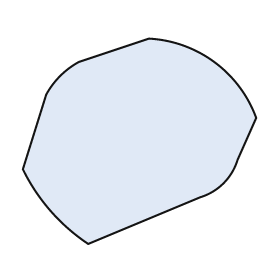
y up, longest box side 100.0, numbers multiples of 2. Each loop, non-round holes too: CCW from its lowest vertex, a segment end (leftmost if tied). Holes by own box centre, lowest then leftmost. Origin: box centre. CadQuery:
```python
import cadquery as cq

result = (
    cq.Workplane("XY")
    .moveTo(-22.0, -44.0)
    .lineTo(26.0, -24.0)
    .threePointArc((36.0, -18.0), (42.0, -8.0))
    .lineTo(50.0, 10.0)
    .threePointArc((32.0, 34.0), (4.0, 44.0))
    .lineTo(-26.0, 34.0)
    .threePointArc((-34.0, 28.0), (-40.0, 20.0))
    .lineTo(-50.0, -12.0)
    .threePointArc((-38.0, -30.0), (-22.0, -44.0))
    .close()
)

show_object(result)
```